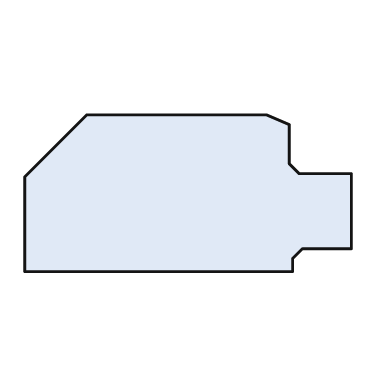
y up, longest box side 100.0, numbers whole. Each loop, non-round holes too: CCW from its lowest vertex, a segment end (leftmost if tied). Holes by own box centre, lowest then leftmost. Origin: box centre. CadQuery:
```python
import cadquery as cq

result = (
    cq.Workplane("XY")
    .moveTo(-50.0, -24.0)
    .lineTo(32.0, -24.0)
    .lineTo(32.0, -20.0)
    .lineTo(35.0, -17.0)
    .lineTo(50.0, -17.0)
    .lineTo(50.0, 6.0)
    .lineTo(34.0, 6.0)
    .lineTo(31.0, 9.0)
    .lineTo(31.0, 21.0)
    .lineTo(24.0, 24.0)
    .lineTo(-31.0, 24.0)
    .lineTo(-50.0, 5.0)
    .close()
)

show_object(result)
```